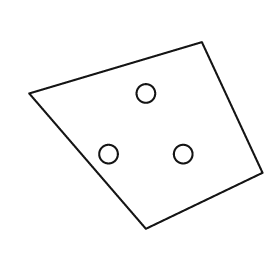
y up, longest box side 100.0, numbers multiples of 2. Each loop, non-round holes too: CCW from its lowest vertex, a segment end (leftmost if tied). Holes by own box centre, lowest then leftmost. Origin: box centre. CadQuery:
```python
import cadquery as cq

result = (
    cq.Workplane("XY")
    .moveTo(0.0, -40.0)
    .lineTo(50.0, -16.0)
    .lineTo(24.0, 40.0)
    .lineTo(-50.0, 18.0)
    .close()
    .moveTo(-16.0, -8.0)
    .circle(4.0)
    .moveTo(16.0, -8.0)
    .circle(4.0)
    .moveTo(0.0, 18.0)
    .circle(4.0)
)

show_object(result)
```